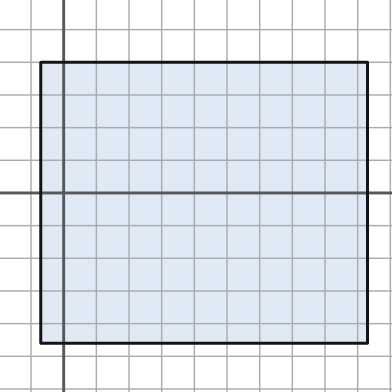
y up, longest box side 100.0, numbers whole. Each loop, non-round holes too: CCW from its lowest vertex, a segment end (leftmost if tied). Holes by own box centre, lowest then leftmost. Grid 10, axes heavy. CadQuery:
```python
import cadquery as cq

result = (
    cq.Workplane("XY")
    .moveTo(-7.0, -46.0)
    .lineTo(93.0, -46.0)
    .lineTo(93.0, 40.0)
    .lineTo(-7.0, 40.0)
    .close()
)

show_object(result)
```